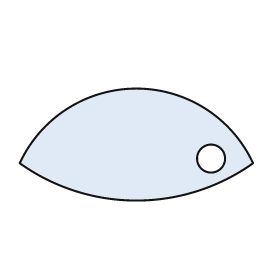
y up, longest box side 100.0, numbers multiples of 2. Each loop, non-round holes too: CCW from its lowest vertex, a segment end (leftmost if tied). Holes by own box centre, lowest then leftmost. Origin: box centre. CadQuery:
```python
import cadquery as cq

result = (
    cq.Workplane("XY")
    .moveTo(-50.0, -8.0)
    .threePointArc((0.0, -24.0), (50.0, -8.0))
    .threePointArc((0.0, 24.0), (-50.0, -8.0))
    .close()
    .moveTo(32.0, -6.0)
    .circle(6.0)
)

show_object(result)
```